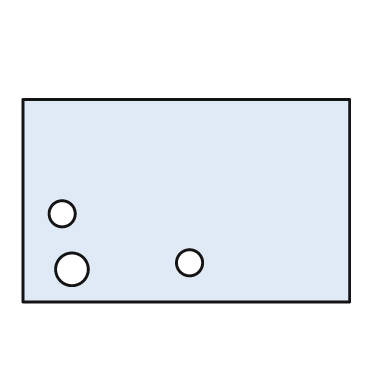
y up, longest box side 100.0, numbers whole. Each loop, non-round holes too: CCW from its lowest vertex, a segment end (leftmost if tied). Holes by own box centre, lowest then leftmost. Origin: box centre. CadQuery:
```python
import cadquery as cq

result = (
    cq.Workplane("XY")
    .moveTo(-50.0, -31.0)
    .lineTo(50.0, -31.0)
    .lineTo(50.0, 31.0)
    .lineTo(-50.0, 31.0)
    .close()
    .moveTo(-35.0, -21.0)
    .circle(5.0)
    .moveTo(1.0, -19.0)
    .circle(4.0)
    .moveTo(-38.0, -4.0)
    .circle(4.0)
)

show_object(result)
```